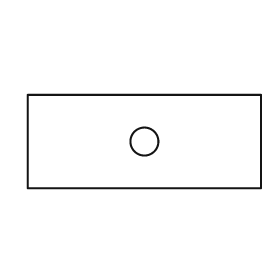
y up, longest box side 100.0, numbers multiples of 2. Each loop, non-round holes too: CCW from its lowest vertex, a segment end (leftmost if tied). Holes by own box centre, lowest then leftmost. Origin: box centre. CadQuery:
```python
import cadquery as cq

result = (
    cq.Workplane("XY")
    .moveTo(-50.0, -20.0)
    .lineTo(50.0, -20.0)
    .lineTo(50.0, 20.0)
    .lineTo(-50.0, 20.0)
    .close()
    .moveTo(0.0, 0.0)
    .circle(6.0)
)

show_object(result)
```